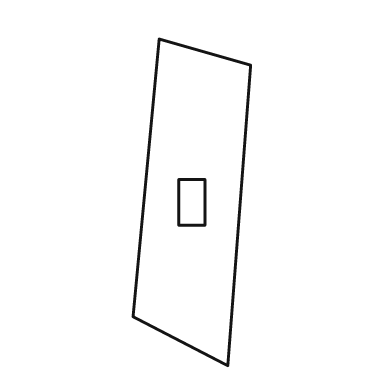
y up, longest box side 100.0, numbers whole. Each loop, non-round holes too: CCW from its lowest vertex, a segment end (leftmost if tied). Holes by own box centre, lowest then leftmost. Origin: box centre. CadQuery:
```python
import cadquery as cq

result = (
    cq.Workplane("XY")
    .moveTo(11.0, -50.0)
    .lineTo(18.0, 42.0)
    .lineTo(-10.0, 50.0)
    .lineTo(-18.0, -35.0)
    .close()
    .moveTo(-4.0, -7.0)
    .lineTo(4.0, -7.0)
    .lineTo(4.0, 7.0)
    .lineTo(-4.0, 7.0)
    .close()
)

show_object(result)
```